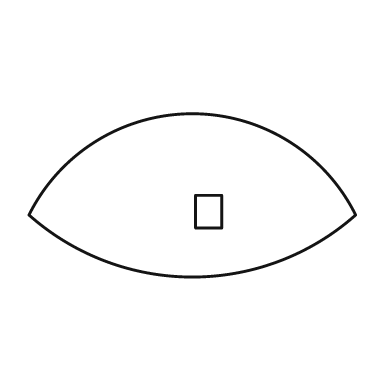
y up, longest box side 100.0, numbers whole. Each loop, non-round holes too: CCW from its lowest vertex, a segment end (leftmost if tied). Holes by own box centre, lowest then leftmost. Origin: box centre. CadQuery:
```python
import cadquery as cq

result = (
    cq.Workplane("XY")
    .moveTo(-50.0, -6.0)
    .threePointArc((0.0, -25.0), (50.0, -6.0))
    .threePointArc((0.0, 25.0), (-50.0, -6.0))
    .close()
    .moveTo(1.0, -10.0)
    .lineTo(9.0, -10.0)
    .lineTo(9.0, 0.0)
    .lineTo(1.0, 0.0)
    .close()
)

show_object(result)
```